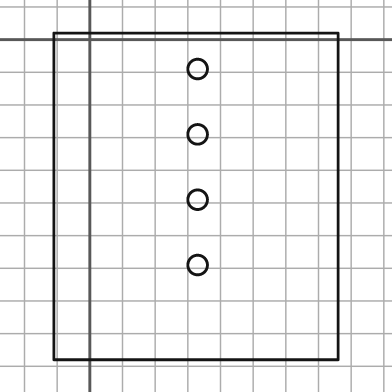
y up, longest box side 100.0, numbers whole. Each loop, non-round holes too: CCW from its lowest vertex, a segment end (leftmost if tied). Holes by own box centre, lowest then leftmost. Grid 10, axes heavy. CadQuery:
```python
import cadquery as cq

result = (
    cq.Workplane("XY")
    .moveTo(-11.0, -98.0)
    .lineTo(76.0, -98.0)
    .lineTo(76.0, 2.0)
    .lineTo(-11.0, 2.0)
    .close()
    .moveTo(33.0, -69.0)
    .circle(3.0)
    .moveTo(33.0, -49.0)
    .circle(3.0)
    .moveTo(33.0, -29.0)
    .circle(3.0)
    .moveTo(33.0, -9.0)
    .circle(3.0)
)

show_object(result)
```